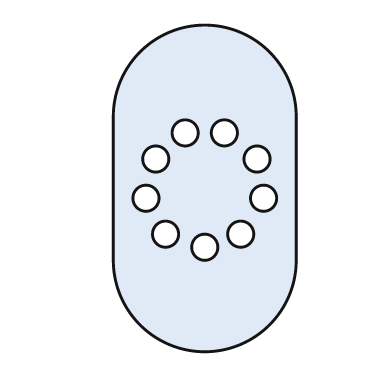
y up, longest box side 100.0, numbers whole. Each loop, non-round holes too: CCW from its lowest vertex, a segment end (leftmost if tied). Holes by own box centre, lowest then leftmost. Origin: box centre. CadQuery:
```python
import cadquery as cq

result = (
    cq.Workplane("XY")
    .moveTo(-28.0, -22.0)
    .threePointArc((0.0, -50.0), (28.0, -22.0))
    .lineTo(28.0, 22.0)
    .threePointArc((0.0, 50.0), (-28.0, 22.0))
    .close()
    .moveTo(0.0, -18.0)
    .circle(4.0)
    .moveTo(-12.0, -14.0)
    .circle(4.0)
    .moveTo(11.0, -14.0)
    .circle(4.0)
    .moveTo(-18.0, -3.0)
    .circle(4.0)
    .moveTo(18.0, -3.0)
    .circle(4.0)
    .moveTo(-15.0, 9.0)
    .circle(4.0)
    .moveTo(16.0, 9.0)
    .circle(4.0)
    .moveTo(-6.0, 17.0)
    .circle(4.0)
    .moveTo(6.0, 17.0)
    .circle(4.0)
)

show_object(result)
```